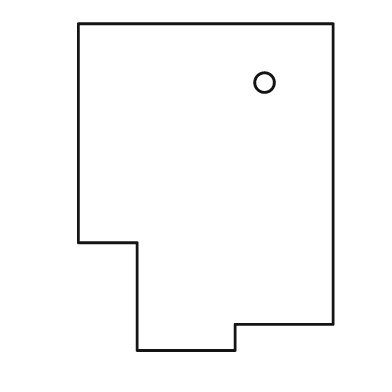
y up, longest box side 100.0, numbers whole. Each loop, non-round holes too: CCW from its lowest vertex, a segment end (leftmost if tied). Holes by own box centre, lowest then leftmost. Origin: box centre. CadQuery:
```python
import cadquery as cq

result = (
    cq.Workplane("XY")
    .moveTo(-21.0, -50.0)
    .lineTo(9.0, -50.0)
    .lineTo(9.0, -42.0)
    .lineTo(39.0, -42.0)
    .lineTo(39.0, 50.0)
    .lineTo(-39.0, 50.0)
    .lineTo(-39.0, -17.0)
    .lineTo(-21.0, -17.0)
    .close()
    .moveTo(18.0, 32.0)
    .circle(3.0)
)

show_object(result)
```